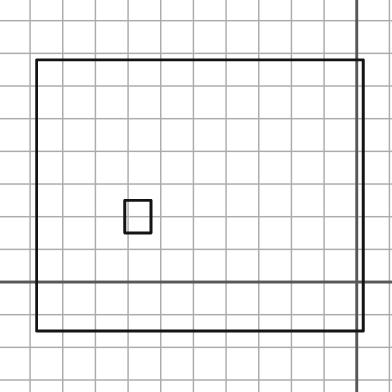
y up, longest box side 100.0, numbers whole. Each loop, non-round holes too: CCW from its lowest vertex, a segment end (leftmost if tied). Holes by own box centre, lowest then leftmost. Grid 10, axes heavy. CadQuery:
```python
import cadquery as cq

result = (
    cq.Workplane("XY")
    .moveTo(-98.0, -15.0)
    .lineTo(2.0, -15.0)
    .lineTo(2.0, 68.0)
    .lineTo(-98.0, 68.0)
    .close()
    .moveTo(-71.0, 15.0)
    .lineTo(-63.0, 15.0)
    .lineTo(-63.0, 25.0)
    .lineTo(-71.0, 25.0)
    .close()
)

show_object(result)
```